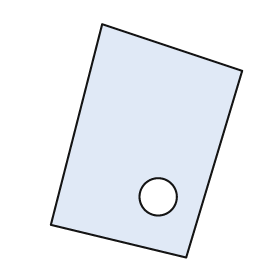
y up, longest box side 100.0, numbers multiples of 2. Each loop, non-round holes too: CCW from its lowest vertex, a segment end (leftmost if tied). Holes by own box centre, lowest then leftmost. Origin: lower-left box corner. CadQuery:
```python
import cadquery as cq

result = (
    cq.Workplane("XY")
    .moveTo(58.0, 0.0)
    .lineTo(82.0, 80.0)
    .lineTo(22.0, 100.0)
    .lineTo(0.0, 14.0)
    .close()
    .moveTo(46.0, 26.0)
    .circle(8.0)
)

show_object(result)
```